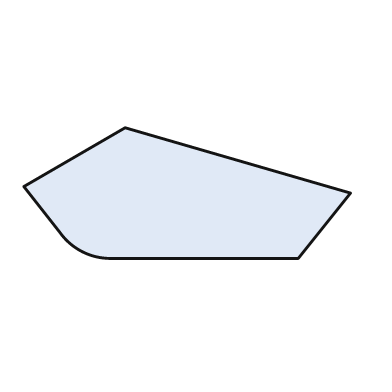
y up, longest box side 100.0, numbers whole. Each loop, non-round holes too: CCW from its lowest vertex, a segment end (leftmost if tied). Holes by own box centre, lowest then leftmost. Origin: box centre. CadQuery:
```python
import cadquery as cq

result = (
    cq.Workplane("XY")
    .moveTo(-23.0, -20.0)
    .lineTo(34.0, -20.0)
    .lineTo(50.0, 0.0)
    .lineTo(-19.0, 20.0)
    .lineTo(-50.0, 2.0)
    .lineTo(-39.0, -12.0)
    .threePointArc((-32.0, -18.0), (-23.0, -20.0))
    .close()
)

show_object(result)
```